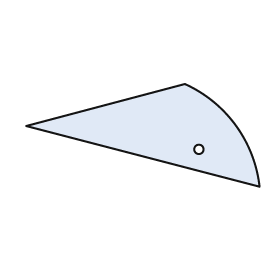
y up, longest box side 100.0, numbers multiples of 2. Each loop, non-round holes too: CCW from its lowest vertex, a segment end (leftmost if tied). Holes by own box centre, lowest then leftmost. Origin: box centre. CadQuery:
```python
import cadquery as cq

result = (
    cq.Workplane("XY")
    .moveTo(50.0, -22.0)
    .threePointArc((40.0, 4.0), (18.0, 22.0))
    .lineTo(-50.0, 4.0)
    .close()
    .moveTo(24.0, -6.0)
    .circle(2.0)
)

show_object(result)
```